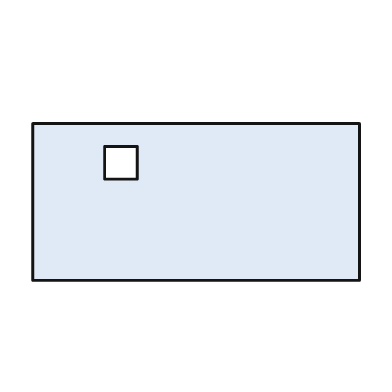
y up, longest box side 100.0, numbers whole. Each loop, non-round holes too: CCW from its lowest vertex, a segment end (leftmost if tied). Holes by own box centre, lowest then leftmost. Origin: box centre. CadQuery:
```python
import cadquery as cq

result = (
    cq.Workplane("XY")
    .moveTo(-50.0, -24.0)
    .lineTo(50.0, -24.0)
    .lineTo(50.0, 24.0)
    .lineTo(-50.0, 24.0)
    .close()
    .moveTo(-28.0, 7.0)
    .lineTo(-18.0, 7.0)
    .lineTo(-18.0, 17.0)
    .lineTo(-28.0, 17.0)
    .close()
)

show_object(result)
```